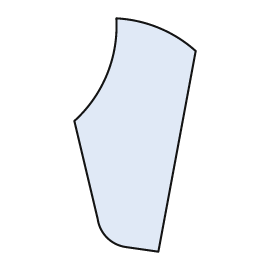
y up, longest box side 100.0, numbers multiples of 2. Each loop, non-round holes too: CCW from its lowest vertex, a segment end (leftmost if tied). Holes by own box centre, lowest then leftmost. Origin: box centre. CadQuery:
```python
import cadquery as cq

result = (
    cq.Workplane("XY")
    .moveTo(10.0, -50.0)
    .lineTo(26.0, 36.0)
    .threePointArc((10.0, 46.0), (-8.0, 50.0))
    .threePointArc((-12.0, 26.0), (-26.0, 6.0))
    .lineTo(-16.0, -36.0)
    .threePointArc((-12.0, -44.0), (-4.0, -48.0))
    .close()
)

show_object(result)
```